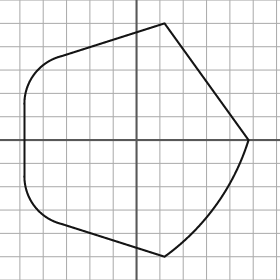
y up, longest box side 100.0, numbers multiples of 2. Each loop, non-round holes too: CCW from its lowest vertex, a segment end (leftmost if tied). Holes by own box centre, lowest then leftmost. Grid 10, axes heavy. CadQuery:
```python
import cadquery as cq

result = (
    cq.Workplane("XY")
    .moveTo(12.0, -50.0)
    .threePointArc((34.0, -28.0), (48.0, 0.0))
    .lineTo(12.0, 50.0)
    .lineTo(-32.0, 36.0)
    .threePointArc((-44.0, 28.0), (-48.0, 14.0))
    .lineTo(-48.0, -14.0)
    .threePointArc((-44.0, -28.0), (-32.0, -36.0))
    .close()
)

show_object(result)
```